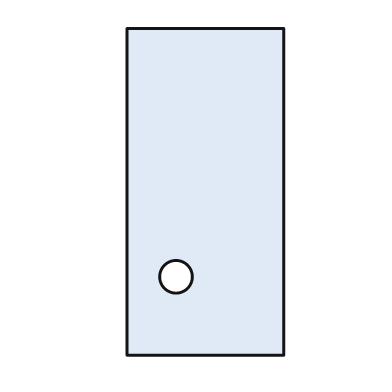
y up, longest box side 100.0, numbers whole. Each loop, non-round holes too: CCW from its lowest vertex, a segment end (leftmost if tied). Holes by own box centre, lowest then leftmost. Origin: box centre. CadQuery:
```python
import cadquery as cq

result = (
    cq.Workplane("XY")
    .moveTo(-24.0, -50.0)
    .lineTo(24.0, -50.0)
    .lineTo(24.0, 50.0)
    .lineTo(-24.0, 50.0)
    .close()
    .moveTo(-9.0, -26.0)
    .circle(5.0)
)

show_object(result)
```